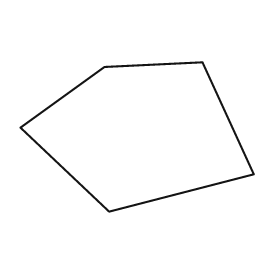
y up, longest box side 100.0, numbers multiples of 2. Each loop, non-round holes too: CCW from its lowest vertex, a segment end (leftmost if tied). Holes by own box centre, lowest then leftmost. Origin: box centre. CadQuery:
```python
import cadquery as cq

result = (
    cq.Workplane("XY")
    .moveTo(-12.0, -32.0)
    .lineTo(50.0, -16.0)
    .lineTo(28.0, 32.0)
    .lineTo(-14.0, 30.0)
    .lineTo(-50.0, 4.0)
    .close()
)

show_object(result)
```